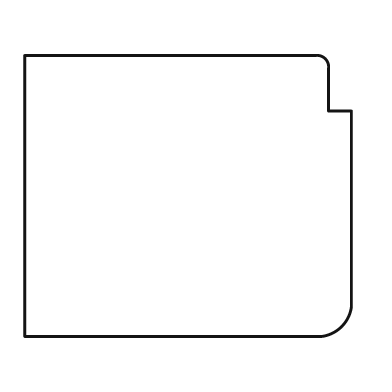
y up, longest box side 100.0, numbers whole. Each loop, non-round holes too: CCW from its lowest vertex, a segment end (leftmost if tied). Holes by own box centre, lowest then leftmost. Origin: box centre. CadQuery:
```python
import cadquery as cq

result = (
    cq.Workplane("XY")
    .moveTo(-50.0, -43.0)
    .lineTo(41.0, -43.0)
    .threePointArc((47.0, -40.0), (50.0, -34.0))
    .lineTo(50.0, 26.0)
    .lineTo(43.0, 26.0)
    .lineTo(43.0, 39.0)
    .threePointArc((42.0, 42.0), (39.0, 43.0))
    .lineTo(-50.0, 43.0)
    .close()
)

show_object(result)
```